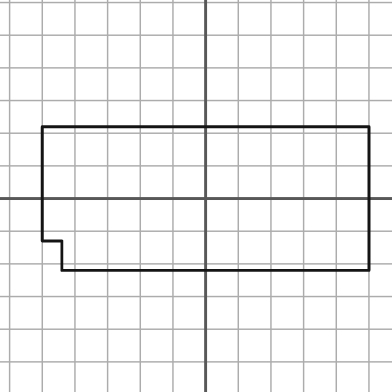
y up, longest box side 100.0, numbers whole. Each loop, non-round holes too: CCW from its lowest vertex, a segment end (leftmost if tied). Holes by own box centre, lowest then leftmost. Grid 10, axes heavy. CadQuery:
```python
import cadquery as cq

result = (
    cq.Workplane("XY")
    .moveTo(-44.0, -22.0)
    .lineTo(50.0, -22.0)
    .lineTo(50.0, 22.0)
    .lineTo(-50.0, 22.0)
    .lineTo(-50.0, -13.0)
    .lineTo(-44.0, -13.0)
    .close()
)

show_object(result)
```